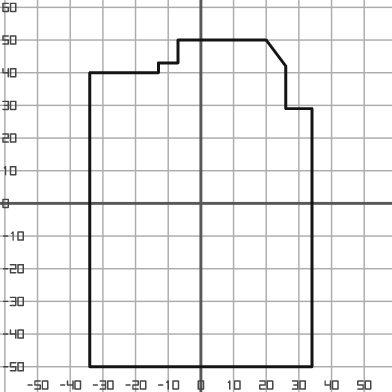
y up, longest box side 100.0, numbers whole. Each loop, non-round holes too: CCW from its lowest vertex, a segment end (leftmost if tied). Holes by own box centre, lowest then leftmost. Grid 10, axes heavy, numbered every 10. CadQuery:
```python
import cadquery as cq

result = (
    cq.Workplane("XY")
    .moveTo(-34.0, -50.0)
    .lineTo(34.0, -50.0)
    .lineTo(34.0, 29.0)
    .lineTo(26.0, 29.0)
    .lineTo(26.0, 42.0)
    .lineTo(20.0, 50.0)
    .lineTo(-7.0, 50.0)
    .lineTo(-7.0, 43.0)
    .lineTo(-13.0, 43.0)
    .lineTo(-13.0, 40.0)
    .lineTo(-34.0, 40.0)
    .close()
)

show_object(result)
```